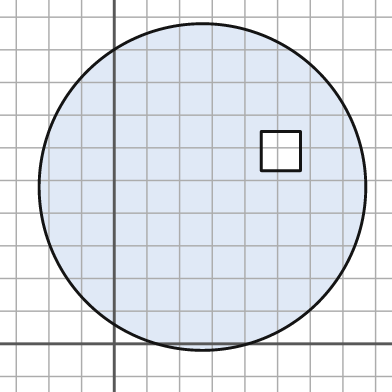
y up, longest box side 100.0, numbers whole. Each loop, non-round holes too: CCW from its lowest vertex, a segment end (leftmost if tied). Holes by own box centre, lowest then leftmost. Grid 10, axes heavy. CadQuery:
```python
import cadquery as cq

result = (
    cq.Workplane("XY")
    .moveTo(27.0, 48.0)
    .circle(50.0)
    .moveTo(45.0, 53.0)
    .lineTo(57.0, 53.0)
    .lineTo(57.0, 65.0)
    .lineTo(45.0, 65.0)
    .close()
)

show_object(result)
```